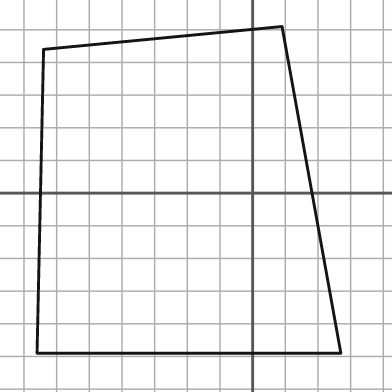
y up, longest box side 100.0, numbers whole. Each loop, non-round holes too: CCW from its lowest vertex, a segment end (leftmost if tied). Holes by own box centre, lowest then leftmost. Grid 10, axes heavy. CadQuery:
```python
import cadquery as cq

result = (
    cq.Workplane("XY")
    .moveTo(-66.0, -49.0)
    .lineTo(27.0, -49.0)
    .lineTo(9.0, 51.0)
    .lineTo(-64.0, 44.0)
    .close()
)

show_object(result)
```